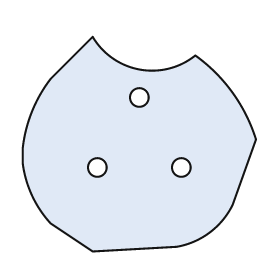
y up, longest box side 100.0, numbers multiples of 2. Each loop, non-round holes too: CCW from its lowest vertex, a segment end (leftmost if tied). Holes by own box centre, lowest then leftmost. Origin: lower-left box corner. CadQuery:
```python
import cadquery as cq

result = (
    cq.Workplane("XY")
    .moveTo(30.0, 0.0)
    .lineTo(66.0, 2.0)
    .threePointArc((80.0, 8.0), (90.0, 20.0))
    .lineTo(100.0, 48.0)
    .threePointArc((90.0, 68.0), (74.0, 84.0))
    .threePointArc((50.0, 78.0), (30.0, 92.0))
    .lineTo(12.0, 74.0)
    .threePointArc((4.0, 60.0), (0.0, 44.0))
    .lineTo(0.0, 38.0)
    .threePointArc((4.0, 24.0), (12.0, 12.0))
    .close()
    .moveTo(32.0, 36.0)
    .circle(4.0)
    .moveTo(68.0, 36.0)
    .circle(4.0)
    .moveTo(50.0, 66.0)
    .circle(4.0)
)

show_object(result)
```